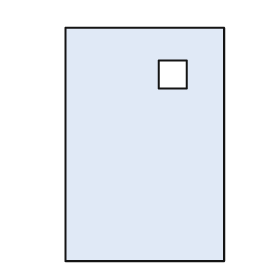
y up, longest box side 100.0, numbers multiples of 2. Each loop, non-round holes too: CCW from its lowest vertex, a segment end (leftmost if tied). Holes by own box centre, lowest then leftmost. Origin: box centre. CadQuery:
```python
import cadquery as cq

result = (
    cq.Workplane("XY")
    .moveTo(-34.0, -50.0)
    .lineTo(34.0, -50.0)
    .lineTo(34.0, 50.0)
    .lineTo(-34.0, 50.0)
    .close()
    .moveTo(6.0, 24.0)
    .lineTo(18.0, 24.0)
    .lineTo(18.0, 36.0)
    .lineTo(6.0, 36.0)
    .close()
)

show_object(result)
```